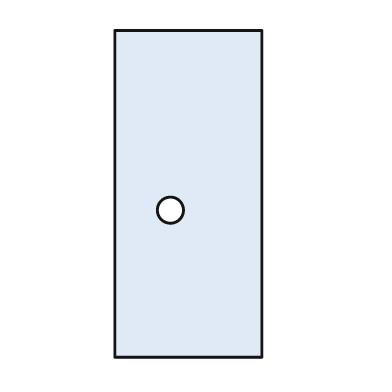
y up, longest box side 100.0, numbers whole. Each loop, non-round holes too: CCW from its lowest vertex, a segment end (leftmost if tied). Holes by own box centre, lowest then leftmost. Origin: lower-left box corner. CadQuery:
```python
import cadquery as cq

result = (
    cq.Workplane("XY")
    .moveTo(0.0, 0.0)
    .lineTo(45.0, 0.0)
    .lineTo(45.0, 100.0)
    .lineTo(0.0, 100.0)
    .close()
    .moveTo(17.0, 45.0)
    .circle(4.0)
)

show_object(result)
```